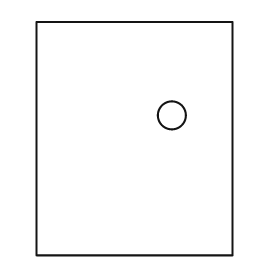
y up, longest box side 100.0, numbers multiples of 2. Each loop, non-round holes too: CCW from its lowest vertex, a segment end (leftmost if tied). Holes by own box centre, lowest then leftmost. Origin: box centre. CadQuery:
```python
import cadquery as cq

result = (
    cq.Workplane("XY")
    .moveTo(-42.0, -50.0)
    .lineTo(42.0, -50.0)
    .lineTo(42.0, 50.0)
    .lineTo(-42.0, 50.0)
    .close()
    .moveTo(16.0, 10.0)
    .circle(6.0)
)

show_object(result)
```